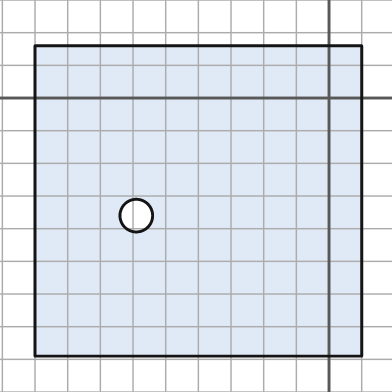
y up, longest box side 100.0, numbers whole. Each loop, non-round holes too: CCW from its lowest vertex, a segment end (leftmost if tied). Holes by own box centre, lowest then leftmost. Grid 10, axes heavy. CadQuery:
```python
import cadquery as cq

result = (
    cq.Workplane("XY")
    .moveTo(-90.0, -79.0)
    .lineTo(10.0, -79.0)
    .lineTo(10.0, 16.0)
    .lineTo(-90.0, 16.0)
    .close()
    .moveTo(-59.0, -36.0)
    .circle(5.0)
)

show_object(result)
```